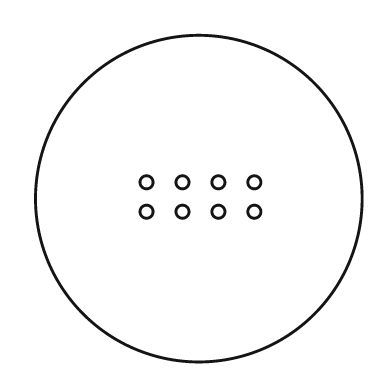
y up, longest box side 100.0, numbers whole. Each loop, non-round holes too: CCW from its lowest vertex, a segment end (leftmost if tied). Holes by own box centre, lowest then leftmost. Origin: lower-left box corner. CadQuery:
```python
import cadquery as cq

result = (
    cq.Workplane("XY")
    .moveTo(50.0, 50.0)
    .circle(50.0)
    .moveTo(34.0, 46.0)
    .circle(2.0)
    .moveTo(45.0, 46.0)
    .circle(2.0)
    .moveTo(56.0, 46.0)
    .circle(2.0)
    .moveTo(67.0, 46.0)
    .circle(2.0)
    .moveTo(34.0, 55.0)
    .circle(2.0)
    .moveTo(45.0, 55.0)
    .circle(2.0)
    .moveTo(56.0, 55.0)
    .circle(2.0)
    .moveTo(67.0, 55.0)
    .circle(2.0)
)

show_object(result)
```